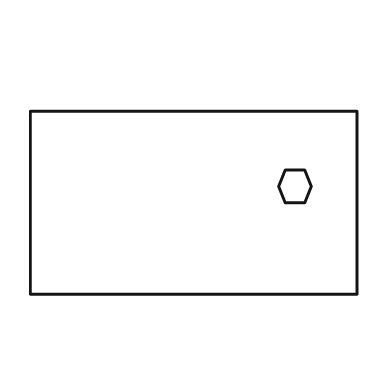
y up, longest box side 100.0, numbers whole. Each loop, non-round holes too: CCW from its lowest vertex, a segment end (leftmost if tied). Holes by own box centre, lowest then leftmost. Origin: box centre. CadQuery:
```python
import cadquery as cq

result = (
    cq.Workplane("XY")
    .moveTo(-50.0, -28.0)
    .lineTo(50.0, -28.0)
    .lineTo(50.0, 28.0)
    .lineTo(-50.0, 28.0)
    .close()
    .moveTo(28.0, 0.0)
    .lineTo(34.0, 0.0)
    .lineTo(36.0, 5.0)
    .lineTo(34.0, 10.0)
    .lineTo(28.0, 10.0)
    .lineTo(26.0, 5.0)
    .close()
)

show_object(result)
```